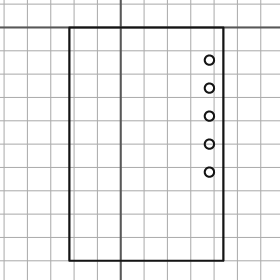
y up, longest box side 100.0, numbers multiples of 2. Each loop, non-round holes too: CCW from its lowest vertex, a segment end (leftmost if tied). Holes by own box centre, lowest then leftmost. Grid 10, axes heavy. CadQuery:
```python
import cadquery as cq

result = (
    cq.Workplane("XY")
    .moveTo(-22.0, -100.0)
    .lineTo(44.0, -100.0)
    .lineTo(44.0, 0.0)
    .lineTo(-22.0, 0.0)
    .close()
    .moveTo(38.0, -62.0)
    .circle(2.0)
    .moveTo(38.0, -50.0)
    .circle(2.0)
    .moveTo(38.0, -38.0)
    .circle(2.0)
    .moveTo(38.0, -26.0)
    .circle(2.0)
    .moveTo(38.0, -14.0)
    .circle(2.0)
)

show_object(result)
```